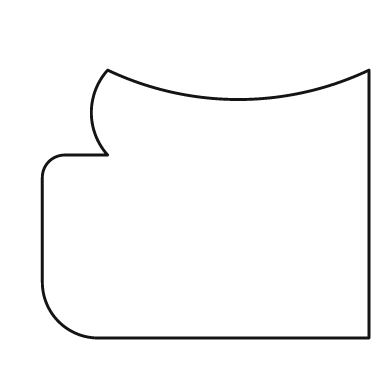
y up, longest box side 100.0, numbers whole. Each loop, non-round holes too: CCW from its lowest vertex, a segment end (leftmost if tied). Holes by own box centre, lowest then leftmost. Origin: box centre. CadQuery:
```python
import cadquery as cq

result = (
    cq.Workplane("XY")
    .moveTo(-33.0, -41.0)
    .lineTo(50.0, -41.0)
    .lineTo(50.0, 41.0)
    .threePointArc((10.0, 32.0), (-30.0, 41.0))
    .threePointArc((-35.0, 28.0), (-30.0, 15.0))
    .lineTo(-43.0, 15.0)
    .threePointArc((-48.0, 13.0), (-50.0, 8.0))
    .lineTo(-50.0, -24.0)
    .threePointArc((-45.0, -36.0), (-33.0, -41.0))
    .close()
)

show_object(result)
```